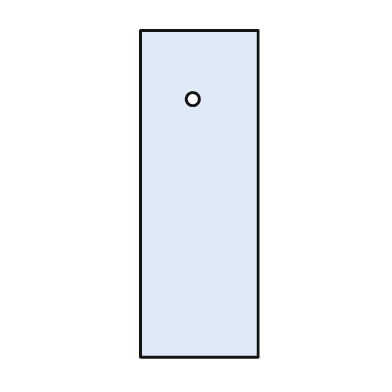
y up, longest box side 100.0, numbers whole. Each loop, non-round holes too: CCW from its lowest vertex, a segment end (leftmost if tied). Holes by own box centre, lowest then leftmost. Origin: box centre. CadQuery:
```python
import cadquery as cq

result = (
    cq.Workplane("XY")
    .moveTo(-18.0, -50.0)
    .lineTo(18.0, -50.0)
    .lineTo(18.0, 50.0)
    .lineTo(-18.0, 50.0)
    .close()
    .moveTo(-2.0, 29.0)
    .circle(2.0)
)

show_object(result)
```